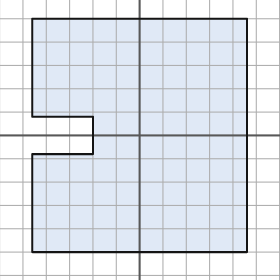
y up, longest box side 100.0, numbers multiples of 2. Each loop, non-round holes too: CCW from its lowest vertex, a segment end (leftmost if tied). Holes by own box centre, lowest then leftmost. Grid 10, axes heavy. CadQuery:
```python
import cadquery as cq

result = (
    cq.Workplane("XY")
    .moveTo(-46.0, -50.0)
    .lineTo(46.0, -50.0)
    .lineTo(46.0, 50.0)
    .lineTo(-46.0, 50.0)
    .lineTo(-46.0, 8.0)
    .lineTo(-20.0, 8.0)
    .lineTo(-20.0, -8.0)
    .lineTo(-46.0, -8.0)
    .close()
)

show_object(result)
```